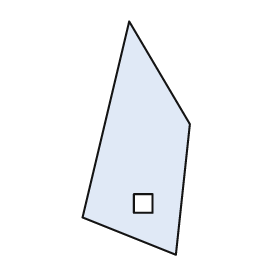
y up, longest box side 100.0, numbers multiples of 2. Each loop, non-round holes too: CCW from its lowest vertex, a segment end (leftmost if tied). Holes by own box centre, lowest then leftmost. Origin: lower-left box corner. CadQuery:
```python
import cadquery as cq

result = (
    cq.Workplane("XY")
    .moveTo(40.0, 0.0)
    .lineTo(46.0, 56.0)
    .lineTo(20.0, 100.0)
    .lineTo(0.0, 16.0)
    .close()
    .moveTo(22.0, 18.0)
    .lineTo(30.0, 18.0)
    .lineTo(30.0, 26.0)
    .lineTo(22.0, 26.0)
    .close()
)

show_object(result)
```